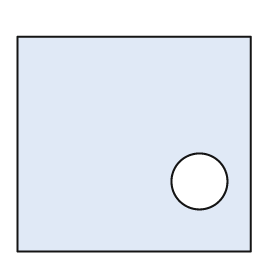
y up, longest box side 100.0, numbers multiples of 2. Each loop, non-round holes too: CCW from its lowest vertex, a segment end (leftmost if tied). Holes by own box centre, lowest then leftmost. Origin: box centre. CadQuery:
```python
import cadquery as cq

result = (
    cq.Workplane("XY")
    .moveTo(-50.0, -46.0)
    .lineTo(50.0, -46.0)
    .lineTo(50.0, 46.0)
    .lineTo(-50.0, 46.0)
    .close()
    .moveTo(28.0, -16.0)
    .circle(12.0)
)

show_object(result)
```